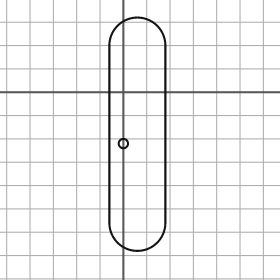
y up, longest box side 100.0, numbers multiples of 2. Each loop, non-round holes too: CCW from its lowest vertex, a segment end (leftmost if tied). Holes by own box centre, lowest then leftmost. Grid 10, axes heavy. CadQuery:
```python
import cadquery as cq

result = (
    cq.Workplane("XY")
    .moveTo(-6.0, -56.0)
    .threePointArc((6.0, -68.0), (18.0, -56.0))
    .lineTo(18.0, 20.0)
    .threePointArc((6.0, 32.0), (-6.0, 20.0))
    .close()
    .moveTo(0.0, -22.0)
    .circle(2.0)
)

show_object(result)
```